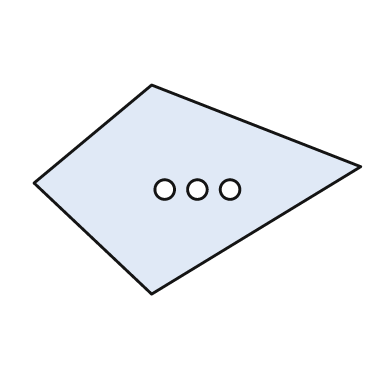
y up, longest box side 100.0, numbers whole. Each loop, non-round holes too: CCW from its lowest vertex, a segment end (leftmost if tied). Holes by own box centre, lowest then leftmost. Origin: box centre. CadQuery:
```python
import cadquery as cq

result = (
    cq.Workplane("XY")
    .moveTo(-14.0, -32.0)
    .lineTo(50.0, 7.0)
    .lineTo(-14.0, 32.0)
    .lineTo(-50.0, 2.0)
    .close()
    .moveTo(-10.0, 0.0)
    .circle(3.0)
    .moveTo(0.0, 0.0)
    .circle(3.0)
    .moveTo(10.0, 0.0)
    .circle(3.0)
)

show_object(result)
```